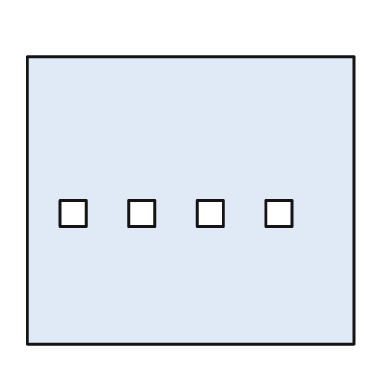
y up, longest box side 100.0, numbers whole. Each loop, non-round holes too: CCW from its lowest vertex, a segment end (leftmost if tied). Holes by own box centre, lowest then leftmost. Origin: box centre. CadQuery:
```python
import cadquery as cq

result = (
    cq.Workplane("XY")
    .moveTo(-50.0, -44.0)
    .lineTo(50.0, -44.0)
    .lineTo(50.0, 44.0)
    .lineTo(-50.0, 44.0)
    .close()
    .moveTo(-40.0, -8.0)
    .lineTo(-32.0, -8.0)
    .lineTo(-32.0, 0.0)
    .lineTo(-40.0, 0.0)
    .close()
    .moveTo(-19.0, -8.0)
    .lineTo(-11.0, -8.0)
    .lineTo(-11.0, 0.0)
    .lineTo(-19.0, 0.0)
    .close()
    .moveTo(2.0, -8.0)
    .lineTo(10.0, -8.0)
    .lineTo(10.0, 0.0)
    .lineTo(2.0, 0.0)
    .close()
    .moveTo(23.0, -8.0)
    .lineTo(31.0, -8.0)
    .lineTo(31.0, 0.0)
    .lineTo(23.0, 0.0)
    .close()
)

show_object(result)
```